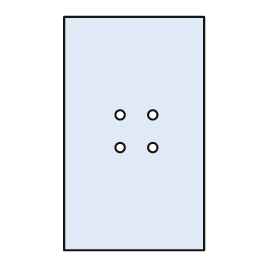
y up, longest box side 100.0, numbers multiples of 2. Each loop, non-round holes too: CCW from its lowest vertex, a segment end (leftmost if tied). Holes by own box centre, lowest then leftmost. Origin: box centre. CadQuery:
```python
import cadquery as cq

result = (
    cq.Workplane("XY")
    .moveTo(-30.0, -50.0)
    .lineTo(30.0, -50.0)
    .lineTo(30.0, 50.0)
    .lineTo(-30.0, 50.0)
    .close()
    .moveTo(-6.0, -6.0)
    .circle(2.0)
    .moveTo(8.0, -6.0)
    .circle(2.0)
    .moveTo(-6.0, 8.0)
    .circle(2.0)
    .moveTo(8.0, 8.0)
    .circle(2.0)
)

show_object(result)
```